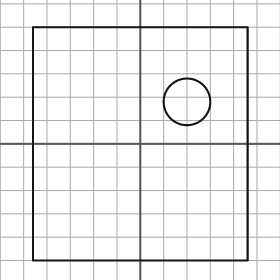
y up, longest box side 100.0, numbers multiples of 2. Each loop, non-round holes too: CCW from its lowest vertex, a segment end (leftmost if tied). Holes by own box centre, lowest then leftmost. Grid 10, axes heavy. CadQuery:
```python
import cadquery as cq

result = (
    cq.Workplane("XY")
    .moveTo(-46.0, -50.0)
    .lineTo(46.0, -50.0)
    .lineTo(46.0, 50.0)
    .lineTo(-46.0, 50.0)
    .close()
    .moveTo(20.0, 18.0)
    .circle(10.0)
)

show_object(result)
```